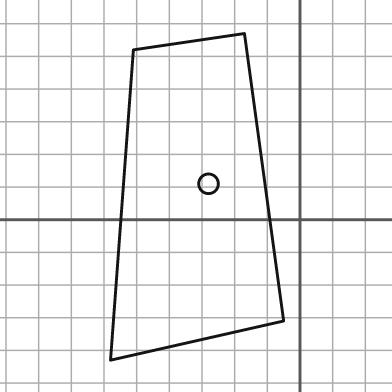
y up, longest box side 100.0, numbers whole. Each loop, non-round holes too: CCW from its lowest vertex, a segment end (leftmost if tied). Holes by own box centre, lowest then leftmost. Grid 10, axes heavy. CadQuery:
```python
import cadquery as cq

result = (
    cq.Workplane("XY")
    .moveTo(-58.0, -43.0)
    .lineTo(-5.0, -31.0)
    .lineTo(-17.0, 57.0)
    .lineTo(-51.0, 52.0)
    .close()
    .moveTo(-28.0, 11.0)
    .circle(3.0)
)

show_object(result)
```